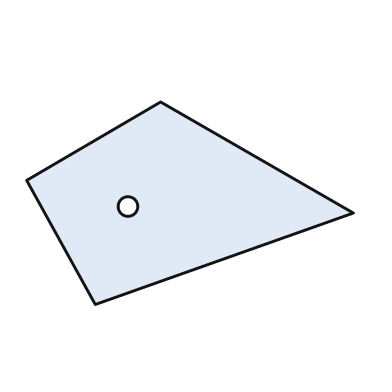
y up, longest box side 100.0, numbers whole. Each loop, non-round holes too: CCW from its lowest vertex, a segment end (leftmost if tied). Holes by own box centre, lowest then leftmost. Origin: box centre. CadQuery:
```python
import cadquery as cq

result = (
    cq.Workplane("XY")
    .moveTo(-29.0, -31.0)
    .lineTo(50.0, -3.0)
    .lineTo(-9.0, 31.0)
    .lineTo(-50.0, 7.0)
    .close()
    .moveTo(-19.0, -1.0)
    .circle(3.0)
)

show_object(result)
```